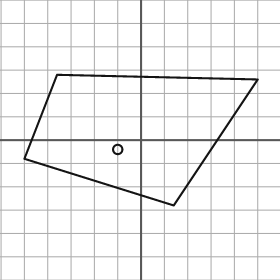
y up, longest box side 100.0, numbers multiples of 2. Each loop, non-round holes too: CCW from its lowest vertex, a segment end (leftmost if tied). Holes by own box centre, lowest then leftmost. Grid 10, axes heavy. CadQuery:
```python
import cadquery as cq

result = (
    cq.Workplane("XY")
    .moveTo(14.0, -28.0)
    .lineTo(50.0, 26.0)
    .lineTo(-36.0, 28.0)
    .lineTo(-50.0, -8.0)
    .close()
    .moveTo(-10.0, -4.0)
    .circle(2.0)
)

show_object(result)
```